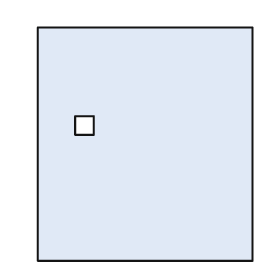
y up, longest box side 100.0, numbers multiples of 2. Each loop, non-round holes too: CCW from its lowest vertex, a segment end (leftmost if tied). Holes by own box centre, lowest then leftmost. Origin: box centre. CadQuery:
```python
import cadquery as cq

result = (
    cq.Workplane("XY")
    .moveTo(-46.0, -50.0)
    .lineTo(46.0, -50.0)
    .lineTo(46.0, 50.0)
    .lineTo(-46.0, 50.0)
    .close()
    .moveTo(-30.0, 4.0)
    .lineTo(-22.0, 4.0)
    .lineTo(-22.0, 12.0)
    .lineTo(-30.0, 12.0)
    .close()
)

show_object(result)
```